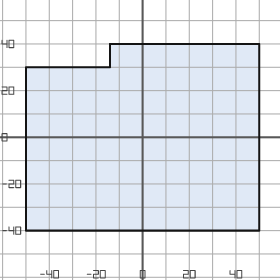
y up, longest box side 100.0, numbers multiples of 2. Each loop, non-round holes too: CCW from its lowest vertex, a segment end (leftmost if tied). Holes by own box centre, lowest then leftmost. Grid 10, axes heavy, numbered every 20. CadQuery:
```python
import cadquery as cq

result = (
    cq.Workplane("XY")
    .moveTo(-50.0, -40.0)
    .lineTo(50.0, -40.0)
    .lineTo(50.0, 40.0)
    .lineTo(-14.0, 40.0)
    .lineTo(-14.0, 30.0)
    .lineTo(-50.0, 30.0)
    .close()
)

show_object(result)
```